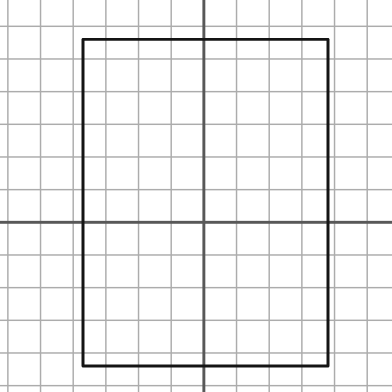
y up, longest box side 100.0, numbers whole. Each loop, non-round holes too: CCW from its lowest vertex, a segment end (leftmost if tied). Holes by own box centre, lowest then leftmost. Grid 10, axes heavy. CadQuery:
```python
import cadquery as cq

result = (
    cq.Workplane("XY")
    .moveTo(-37.0, -44.0)
    .lineTo(38.0, -44.0)
    .lineTo(38.0, 56.0)
    .lineTo(-37.0, 56.0)
    .close()
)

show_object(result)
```